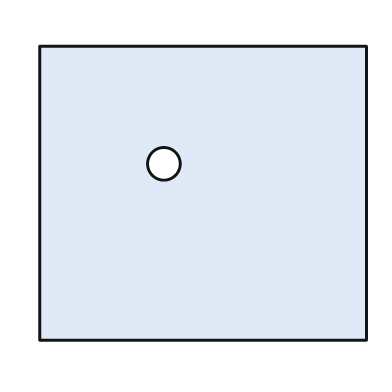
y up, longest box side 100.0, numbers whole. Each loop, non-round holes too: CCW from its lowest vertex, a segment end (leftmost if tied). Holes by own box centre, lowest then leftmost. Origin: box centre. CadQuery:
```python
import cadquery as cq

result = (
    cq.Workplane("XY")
    .moveTo(-50.0, -45.0)
    .lineTo(50.0, -45.0)
    .lineTo(50.0, 45.0)
    .lineTo(-50.0, 45.0)
    .close()
    .moveTo(-12.0, 9.0)
    .circle(5.0)
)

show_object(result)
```